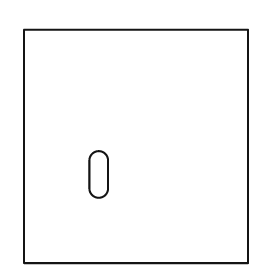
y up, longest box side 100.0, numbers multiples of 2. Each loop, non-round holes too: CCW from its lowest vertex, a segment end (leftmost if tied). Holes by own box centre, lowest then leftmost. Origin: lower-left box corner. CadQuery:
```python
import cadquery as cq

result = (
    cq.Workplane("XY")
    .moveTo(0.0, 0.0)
    .lineTo(96.0, 0.0)
    .lineTo(96.0, 100.0)
    .lineTo(0.0, 100.0)
    .close()
    .moveTo(28.0, 32.0)
    .threePointArc((32.0, 28.0), (36.0, 32.0))
    .lineTo(36.0, 44.0)
    .threePointArc((32.0, 48.0), (28.0, 44.0))
    .close()
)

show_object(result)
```